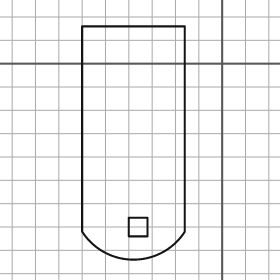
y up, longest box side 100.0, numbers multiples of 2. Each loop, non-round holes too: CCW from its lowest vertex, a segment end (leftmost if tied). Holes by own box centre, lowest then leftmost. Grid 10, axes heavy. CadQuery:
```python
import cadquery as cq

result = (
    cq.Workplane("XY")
    .moveTo(-60.0, -72.0)
    .threePointArc((-38.0, -84.0), (-16.0, -72.0))
    .lineTo(-16.0, 16.0)
    .lineTo(-60.0, 16.0)
    .close()
    .moveTo(-40.0, -74.0)
    .lineTo(-32.0, -74.0)
    .lineTo(-32.0, -66.0)
    .lineTo(-40.0, -66.0)
    .close()
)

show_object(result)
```